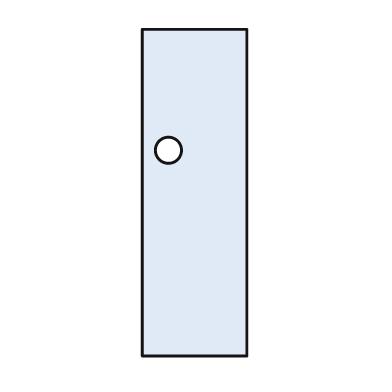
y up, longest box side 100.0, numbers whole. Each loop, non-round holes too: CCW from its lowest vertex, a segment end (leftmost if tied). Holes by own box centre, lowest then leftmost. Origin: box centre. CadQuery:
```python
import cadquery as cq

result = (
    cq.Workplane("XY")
    .moveTo(-16.0, -50.0)
    .lineTo(16.0, -50.0)
    .lineTo(16.0, 50.0)
    .lineTo(-16.0, 50.0)
    .close()
    .moveTo(-8.0, 13.0)
    .circle(4.0)
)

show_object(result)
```